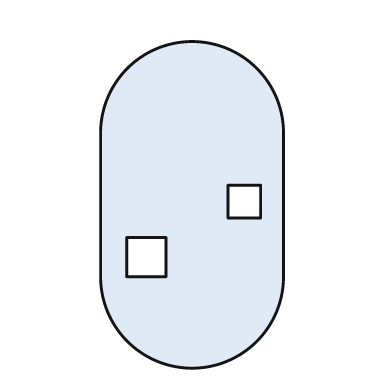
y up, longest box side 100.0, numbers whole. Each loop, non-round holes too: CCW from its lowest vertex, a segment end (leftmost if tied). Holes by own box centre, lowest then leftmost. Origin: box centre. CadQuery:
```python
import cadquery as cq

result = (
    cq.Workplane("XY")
    .moveTo(-28.0, -22.0)
    .threePointArc((0.0, -50.0), (28.0, -22.0))
    .lineTo(28.0, 22.0)
    .threePointArc((0.0, 50.0), (-28.0, 22.0))
    .close()
    .moveTo(-20.0, -22.0)
    .lineTo(-8.0, -22.0)
    .lineTo(-8.0, -10.0)
    .lineTo(-20.0, -10.0)
    .close()
    .moveTo(11.0, -4.0)
    .lineTo(21.0, -4.0)
    .lineTo(21.0, 6.0)
    .lineTo(11.0, 6.0)
    .close()
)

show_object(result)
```